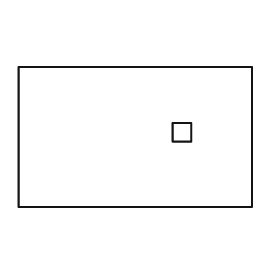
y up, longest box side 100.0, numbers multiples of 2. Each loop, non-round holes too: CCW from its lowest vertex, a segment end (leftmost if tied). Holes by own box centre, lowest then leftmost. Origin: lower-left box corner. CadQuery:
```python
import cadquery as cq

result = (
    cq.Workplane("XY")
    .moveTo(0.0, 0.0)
    .lineTo(100.0, 0.0)
    .lineTo(100.0, 60.0)
    .lineTo(0.0, 60.0)
    .close()
    .moveTo(66.0, 28.0)
    .lineTo(74.0, 28.0)
    .lineTo(74.0, 36.0)
    .lineTo(66.0, 36.0)
    .close()
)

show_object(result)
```